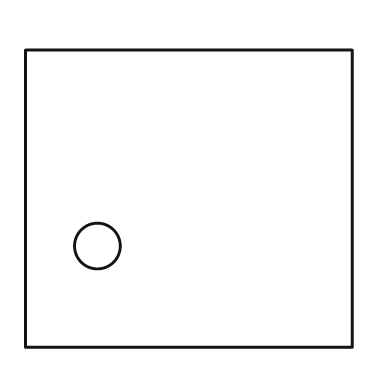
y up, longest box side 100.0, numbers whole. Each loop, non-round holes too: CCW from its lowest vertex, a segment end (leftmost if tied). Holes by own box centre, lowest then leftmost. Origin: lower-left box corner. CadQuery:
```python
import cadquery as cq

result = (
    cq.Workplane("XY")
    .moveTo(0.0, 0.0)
    .lineTo(100.0, 0.0)
    .lineTo(100.0, 91.0)
    .lineTo(0.0, 91.0)
    .close()
    .moveTo(22.0, 31.0)
    .circle(7.0)
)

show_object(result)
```